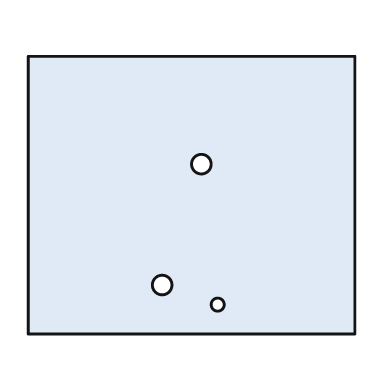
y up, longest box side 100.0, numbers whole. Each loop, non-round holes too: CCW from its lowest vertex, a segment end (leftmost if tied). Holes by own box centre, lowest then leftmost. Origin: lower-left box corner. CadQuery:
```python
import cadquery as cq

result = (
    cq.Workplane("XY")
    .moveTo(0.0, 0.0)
    .lineTo(100.0, 0.0)
    .lineTo(100.0, 85.0)
    .lineTo(0.0, 85.0)
    .close()
    .moveTo(58.0, 9.0)
    .circle(2.0)
    .moveTo(41.0, 15.0)
    .circle(3.0)
    .moveTo(53.0, 52.0)
    .circle(3.0)
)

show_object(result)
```